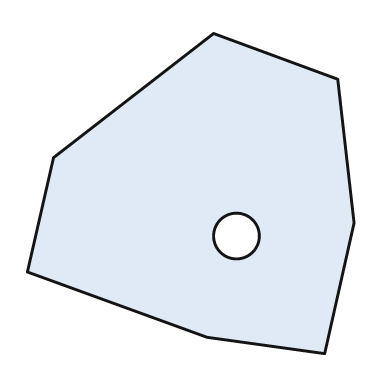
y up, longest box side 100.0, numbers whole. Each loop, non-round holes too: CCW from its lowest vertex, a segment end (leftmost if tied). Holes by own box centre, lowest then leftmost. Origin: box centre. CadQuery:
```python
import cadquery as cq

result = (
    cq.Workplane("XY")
    .moveTo(41.0, -49.0)
    .lineTo(50.0, -9.0)
    .lineTo(45.0, 35.0)
    .lineTo(7.0, 49.0)
    .lineTo(-42.0, 11.0)
    .lineTo(-50.0, -24.0)
    .lineTo(5.0, -44.0)
    .close()
    .moveTo(14.0, -13.0)
    .circle(7.0)
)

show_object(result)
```